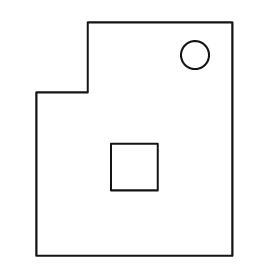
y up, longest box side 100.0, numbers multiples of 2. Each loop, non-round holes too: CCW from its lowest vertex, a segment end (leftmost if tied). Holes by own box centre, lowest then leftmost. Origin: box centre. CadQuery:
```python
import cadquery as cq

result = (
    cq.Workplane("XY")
    .moveTo(-42.0, -50.0)
    .lineTo(42.0, -50.0)
    .lineTo(42.0, 50.0)
    .lineTo(-20.0, 50.0)
    .lineTo(-20.0, 20.0)
    .lineTo(-42.0, 20.0)
    .close()
    .moveTo(-10.0, -22.0)
    .lineTo(10.0, -22.0)
    .lineTo(10.0, -2.0)
    .lineTo(-10.0, -2.0)
    .close()
    .moveTo(26.0, 36.0)
    .circle(6.0)
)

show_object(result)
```